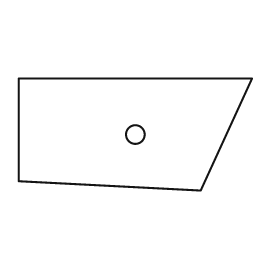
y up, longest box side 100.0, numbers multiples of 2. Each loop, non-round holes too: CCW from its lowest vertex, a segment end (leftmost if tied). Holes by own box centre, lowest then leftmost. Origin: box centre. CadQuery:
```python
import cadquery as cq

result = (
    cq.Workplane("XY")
    .moveTo(28.0, -24.0)
    .lineTo(50.0, 24.0)
    .lineTo(-50.0, 24.0)
    .lineTo(-50.0, -20.0)
    .close()
    .moveTo(0.0, 0.0)
    .circle(4.0)
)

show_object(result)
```